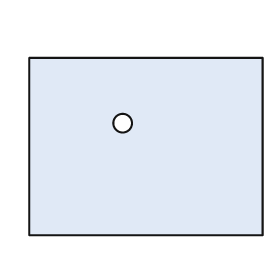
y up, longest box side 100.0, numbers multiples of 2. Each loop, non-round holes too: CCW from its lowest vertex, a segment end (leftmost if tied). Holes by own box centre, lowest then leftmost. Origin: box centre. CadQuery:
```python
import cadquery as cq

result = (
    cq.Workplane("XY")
    .moveTo(-50.0, -38.0)
    .lineTo(50.0, -38.0)
    .lineTo(50.0, 38.0)
    .lineTo(-50.0, 38.0)
    .close()
    .moveTo(-10.0, 10.0)
    .circle(4.0)
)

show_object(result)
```